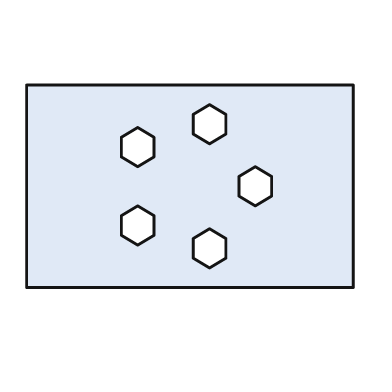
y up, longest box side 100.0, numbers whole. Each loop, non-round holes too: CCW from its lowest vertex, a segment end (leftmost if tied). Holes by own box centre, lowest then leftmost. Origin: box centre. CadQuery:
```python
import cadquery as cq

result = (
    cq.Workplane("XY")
    .moveTo(-50.0, -31.0)
    .lineTo(50.0, -31.0)
    .lineTo(50.0, 31.0)
    .lineTo(-50.0, 31.0)
    .close()
    .moveTo(6.0, -25.0)
    .lineTo(11.0, -22.0)
    .lineTo(11.0, -16.0)
    .lineTo(6.0, -13.0)
    .lineTo(1.0, -16.0)
    .lineTo(1.0, -22.0)
    .close()
    .moveTo(-16.0, -18.0)
    .lineTo(-11.0, -15.0)
    .lineTo(-11.0, -9.0)
    .lineTo(-16.0, -6.0)
    .lineTo(-21.0, -9.0)
    .lineTo(-21.0, -15.0)
    .close()
    .moveTo(20.0, -6.0)
    .lineTo(25.0, -3.0)
    .lineTo(25.0, 3.0)
    .lineTo(20.0, 6.0)
    .lineTo(15.0, 3.0)
    .lineTo(15.0, -3.0)
    .close()
    .moveTo(-16.0, 6.0)
    .lineTo(-11.0, 9.0)
    .lineTo(-11.0, 15.0)
    .lineTo(-16.0, 18.0)
    .lineTo(-21.0, 15.0)
    .lineTo(-21.0, 9.0)
    .close()
    .moveTo(6.0, 13.0)
    .lineTo(11.0, 16.0)
    .lineTo(11.0, 22.0)
    .lineTo(6.0, 25.0)
    .lineTo(1.0, 22.0)
    .lineTo(1.0, 16.0)
    .close()
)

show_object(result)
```